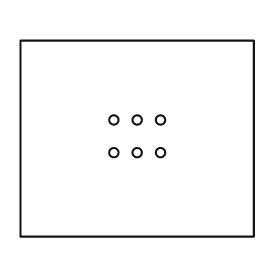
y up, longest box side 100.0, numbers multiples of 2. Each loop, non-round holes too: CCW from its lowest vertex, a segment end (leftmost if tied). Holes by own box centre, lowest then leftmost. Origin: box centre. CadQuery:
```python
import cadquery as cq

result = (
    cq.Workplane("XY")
    .moveTo(-50.0, -42.0)
    .lineTo(50.0, -42.0)
    .lineTo(50.0, 42.0)
    .lineTo(-50.0, 42.0)
    .close()
    .moveTo(-10.0, -6.0)
    .circle(2.0)
    .moveTo(0.0, -6.0)
    .circle(2.0)
    .moveTo(10.0, -6.0)
    .circle(2.0)
    .moveTo(-10.0, 8.0)
    .circle(2.0)
    .moveTo(0.0, 8.0)
    .circle(2.0)
    .moveTo(10.0, 8.0)
    .circle(2.0)
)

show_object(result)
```